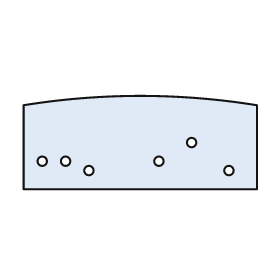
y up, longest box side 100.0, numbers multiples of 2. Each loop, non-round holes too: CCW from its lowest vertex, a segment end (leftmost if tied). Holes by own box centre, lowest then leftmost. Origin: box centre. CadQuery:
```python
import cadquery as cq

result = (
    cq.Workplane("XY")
    .moveTo(-50.0, -20.0)
    .lineTo(50.0, -20.0)
    .lineTo(50.0, 16.0)
    .threePointArc((0.0, 20.0), (-50.0, 16.0))
    .close()
    .moveTo(-22.0, -12.0)
    .circle(2.0)
    .moveTo(38.0, -12.0)
    .circle(2.0)
    .moveTo(-42.0, -8.0)
    .circle(2.0)
    .moveTo(-32.0, -8.0)
    .circle(2.0)
    .moveTo(8.0, -8.0)
    .circle(2.0)
    .moveTo(22.0, 0.0)
    .circle(2.0)
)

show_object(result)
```